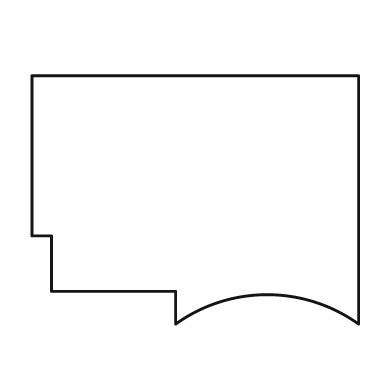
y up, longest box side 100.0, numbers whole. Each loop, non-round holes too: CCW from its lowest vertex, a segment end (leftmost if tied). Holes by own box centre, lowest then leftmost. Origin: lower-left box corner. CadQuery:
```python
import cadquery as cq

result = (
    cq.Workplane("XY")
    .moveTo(44.0, 0.0)
    .threePointArc((72.0, 9.0), (100.0, 0.0))
    .lineTo(100.0, 76.0)
    .lineTo(0.0, 76.0)
    .lineTo(0.0, 27.0)
    .lineTo(6.0, 27.0)
    .lineTo(6.0, 10.0)
    .lineTo(44.0, 10.0)
    .close()
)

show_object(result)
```